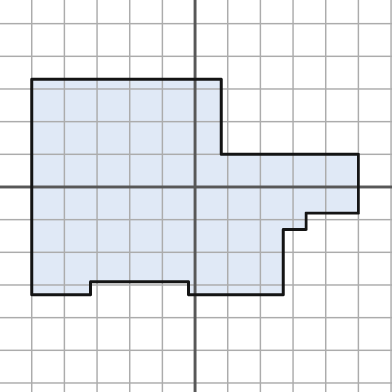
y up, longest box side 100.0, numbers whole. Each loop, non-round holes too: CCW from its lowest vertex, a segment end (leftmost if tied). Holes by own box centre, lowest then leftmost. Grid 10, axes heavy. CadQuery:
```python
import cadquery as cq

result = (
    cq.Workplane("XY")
    .moveTo(-50.0, -33.0)
    .lineTo(-32.0, -33.0)
    .lineTo(-32.0, -29.0)
    .lineTo(-2.0, -29.0)
    .lineTo(-2.0, -33.0)
    .lineTo(27.0, -33.0)
    .lineTo(27.0, -13.0)
    .lineTo(34.0, -13.0)
    .lineTo(34.0, -8.0)
    .lineTo(50.0, -8.0)
    .lineTo(50.0, 10.0)
    .lineTo(8.0, 10.0)
    .lineTo(8.0, 33.0)
    .lineTo(-50.0, 33.0)
    .close()
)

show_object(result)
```